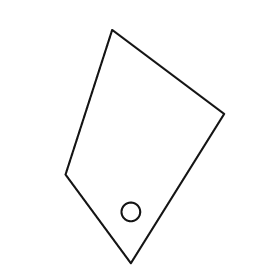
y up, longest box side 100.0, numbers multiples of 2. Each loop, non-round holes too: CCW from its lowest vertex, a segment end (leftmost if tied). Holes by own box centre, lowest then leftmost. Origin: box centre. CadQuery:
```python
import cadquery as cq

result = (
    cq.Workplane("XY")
    .moveTo(-6.0, -50.0)
    .lineTo(34.0, 14.0)
    .lineTo(-14.0, 50.0)
    .lineTo(-34.0, -12.0)
    .close()
    .moveTo(-6.0, -28.0)
    .circle(4.0)
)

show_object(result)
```